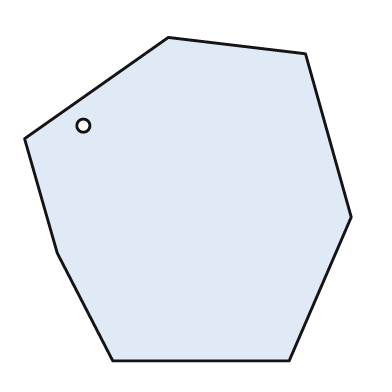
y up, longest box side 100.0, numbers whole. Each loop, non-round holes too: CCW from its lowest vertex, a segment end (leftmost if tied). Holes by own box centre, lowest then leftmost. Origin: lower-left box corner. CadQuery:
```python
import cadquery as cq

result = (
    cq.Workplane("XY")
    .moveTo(27.0, 0.0)
    .lineTo(81.0, 0.0)
    .lineTo(100.0, 44.0)
    .lineTo(86.0, 94.0)
    .lineTo(44.0, 99.0)
    .lineTo(0.0, 68.0)
    .lineTo(10.0, 33.0)
    .close()
    .moveTo(18.0, 72.0)
    .circle(2.0)
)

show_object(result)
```